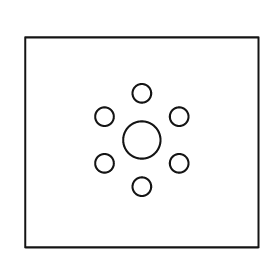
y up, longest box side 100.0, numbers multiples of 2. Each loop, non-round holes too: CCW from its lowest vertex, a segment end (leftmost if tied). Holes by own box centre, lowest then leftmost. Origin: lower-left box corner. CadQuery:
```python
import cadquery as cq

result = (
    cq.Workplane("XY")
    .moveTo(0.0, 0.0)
    .lineTo(100.0, 0.0)
    .lineTo(100.0, 90.0)
    .lineTo(0.0, 90.0)
    .close()
    .moveTo(50.0, 26.0)
    .circle(4.0)
    .moveTo(34.0, 36.0)
    .circle(4.0)
    .moveTo(66.0, 36.0)
    .circle(4.0)
    .moveTo(50.0, 46.0)
    .circle(8.0)
    .moveTo(34.0, 56.0)
    .circle(4.0)
    .moveTo(66.0, 56.0)
    .circle(4.0)
    .moveTo(50.0, 66.0)
    .circle(4.0)
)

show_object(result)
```